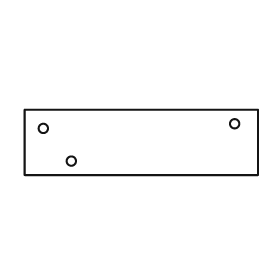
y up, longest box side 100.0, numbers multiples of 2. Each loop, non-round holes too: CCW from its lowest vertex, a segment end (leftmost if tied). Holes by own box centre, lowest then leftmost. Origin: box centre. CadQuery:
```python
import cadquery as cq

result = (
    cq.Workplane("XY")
    .moveTo(-50.0, -14.0)
    .lineTo(50.0, -14.0)
    .lineTo(50.0, 14.0)
    .lineTo(-50.0, 14.0)
    .close()
    .moveTo(-30.0, -8.0)
    .circle(2.0)
    .moveTo(-42.0, 6.0)
    .circle(2.0)
    .moveTo(40.0, 8.0)
    .circle(2.0)
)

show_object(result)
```